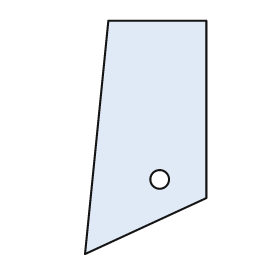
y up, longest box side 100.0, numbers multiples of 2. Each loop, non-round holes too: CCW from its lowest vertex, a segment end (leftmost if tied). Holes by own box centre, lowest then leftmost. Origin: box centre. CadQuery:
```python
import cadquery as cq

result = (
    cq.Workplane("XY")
    .moveTo(-26.0, -50.0)
    .lineTo(26.0, -26.0)
    .lineTo(26.0, 50.0)
    .lineTo(-16.0, 50.0)
    .close()
    .moveTo(6.0, -18.0)
    .circle(4.0)
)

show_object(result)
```